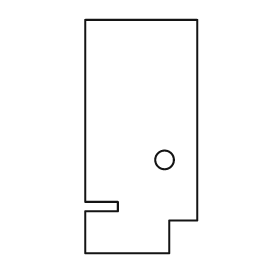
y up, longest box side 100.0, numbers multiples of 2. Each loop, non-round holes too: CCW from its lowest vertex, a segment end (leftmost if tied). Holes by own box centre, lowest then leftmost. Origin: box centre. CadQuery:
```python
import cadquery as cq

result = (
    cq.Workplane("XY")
    .moveTo(-24.0, -50.0)
    .lineTo(12.0, -50.0)
    .lineTo(12.0, -36.0)
    .lineTo(24.0, -36.0)
    .lineTo(24.0, 50.0)
    .lineTo(-24.0, 50.0)
    .lineTo(-24.0, -28.0)
    .lineTo(-10.0, -28.0)
    .lineTo(-10.0, -32.0)
    .lineTo(-24.0, -32.0)
    .close()
    .moveTo(10.0, -10.0)
    .circle(4.0)
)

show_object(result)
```